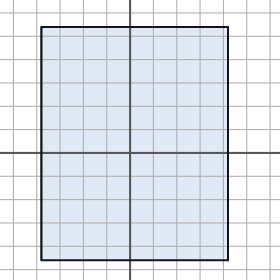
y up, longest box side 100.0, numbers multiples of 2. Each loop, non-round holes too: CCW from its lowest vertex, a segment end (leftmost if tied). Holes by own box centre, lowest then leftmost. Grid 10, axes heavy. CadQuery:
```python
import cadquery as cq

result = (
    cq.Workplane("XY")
    .moveTo(-38.0, -46.0)
    .lineTo(42.0, -46.0)
    .lineTo(42.0, 54.0)
    .lineTo(-38.0, 54.0)
    .close()
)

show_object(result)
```